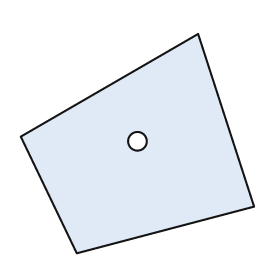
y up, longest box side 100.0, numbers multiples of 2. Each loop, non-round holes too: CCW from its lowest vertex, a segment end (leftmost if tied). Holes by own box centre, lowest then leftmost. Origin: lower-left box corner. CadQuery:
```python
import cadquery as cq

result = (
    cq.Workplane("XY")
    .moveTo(24.0, 0.0)
    .lineTo(100.0, 20.0)
    .lineTo(76.0, 94.0)
    .lineTo(0.0, 50.0)
    .close()
    .moveTo(50.0, 48.0)
    .circle(4.0)
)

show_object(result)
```